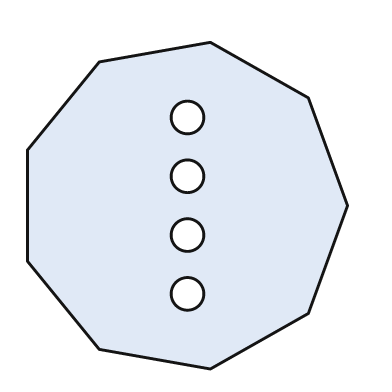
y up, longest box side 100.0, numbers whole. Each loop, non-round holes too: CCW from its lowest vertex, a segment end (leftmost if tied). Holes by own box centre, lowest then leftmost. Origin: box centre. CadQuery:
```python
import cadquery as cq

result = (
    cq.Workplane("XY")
    .moveTo(7.0, -50.0)
    .lineTo(37.0, -33.0)
    .lineTo(49.0, 0.0)
    .lineTo(37.0, 33.0)
    .lineTo(7.0, 50.0)
    .lineTo(-27.0, 44.0)
    .lineTo(-49.0, 17.0)
    .lineTo(-49.0, -17.0)
    .lineTo(-27.0, -44.0)
    .close()
    .moveTo(0.0, -27.0)
    .circle(5.0)
    .moveTo(0.0, -9.0)
    .circle(5.0)
    .moveTo(0.0, 9.0)
    .circle(5.0)
    .moveTo(0.0, 27.0)
    .circle(5.0)
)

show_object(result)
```